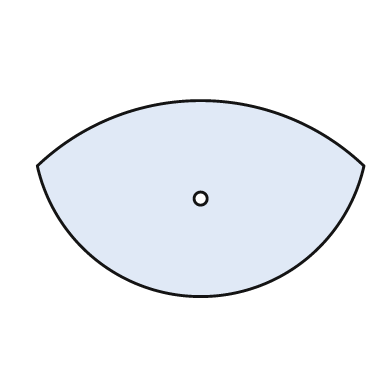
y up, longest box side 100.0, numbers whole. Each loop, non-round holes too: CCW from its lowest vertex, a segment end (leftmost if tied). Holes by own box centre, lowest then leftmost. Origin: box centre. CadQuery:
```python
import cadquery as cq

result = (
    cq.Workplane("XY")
    .moveTo(-50.0, 10.0)
    .threePointArc((0.0, -30.0), (50.0, 10.0))
    .threePointArc((0.0, 30.0), (-50.0, 10.0))
    .close()
    .moveTo(0.0, 0.0)
    .circle(2.0)
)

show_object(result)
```